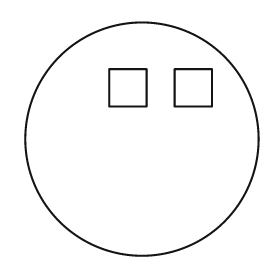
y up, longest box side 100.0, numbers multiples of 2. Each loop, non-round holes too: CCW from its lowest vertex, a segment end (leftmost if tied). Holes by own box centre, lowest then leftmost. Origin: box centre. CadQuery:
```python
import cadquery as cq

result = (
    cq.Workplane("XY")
    .moveTo(0.0, 0.0)
    .circle(50.0)
    .moveTo(-14.0, 14.0)
    .lineTo(2.0, 14.0)
    .lineTo(2.0, 30.0)
    .lineTo(-14.0, 30.0)
    .close()
    .moveTo(14.0, 14.0)
    .lineTo(30.0, 14.0)
    .lineTo(30.0, 30.0)
    .lineTo(14.0, 30.0)
    .close()
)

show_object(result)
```